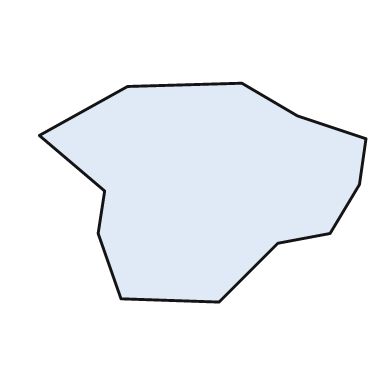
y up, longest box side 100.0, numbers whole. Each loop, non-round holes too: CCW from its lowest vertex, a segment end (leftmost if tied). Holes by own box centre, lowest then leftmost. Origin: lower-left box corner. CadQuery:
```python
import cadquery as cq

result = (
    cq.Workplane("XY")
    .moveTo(55.0, 0.0)
    .lineTo(73.0, 18.0)
    .lineTo(89.0, 21.0)
    .lineTo(98.0, 36.0)
    .lineTo(100.0, 50.0)
    .lineTo(79.0, 57.0)
    .lineTo(62.0, 67.0)
    .lineTo(27.0, 66.0)
    .lineTo(0.0, 51.0)
    .lineTo(20.0, 34.0)
    .lineTo(18.0, 21.0)
    .lineTo(25.0, 1.0)
    .close()
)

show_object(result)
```